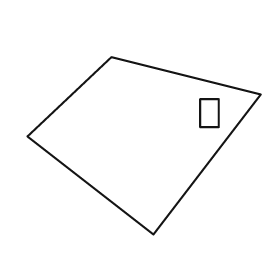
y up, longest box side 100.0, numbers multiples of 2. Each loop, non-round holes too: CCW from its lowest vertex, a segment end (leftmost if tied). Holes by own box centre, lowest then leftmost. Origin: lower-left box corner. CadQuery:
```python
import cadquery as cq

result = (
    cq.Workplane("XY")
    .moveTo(54.0, 0.0)
    .lineTo(100.0, 60.0)
    .lineTo(36.0, 76.0)
    .lineTo(0.0, 42.0)
    .close()
    .moveTo(74.0, 46.0)
    .lineTo(82.0, 46.0)
    .lineTo(82.0, 58.0)
    .lineTo(74.0, 58.0)
    .close()
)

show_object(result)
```